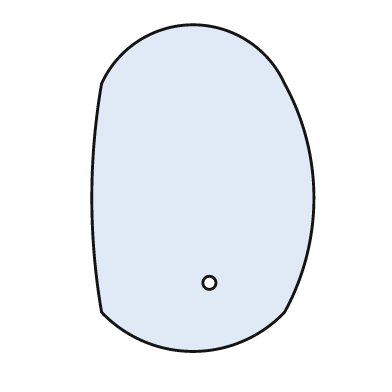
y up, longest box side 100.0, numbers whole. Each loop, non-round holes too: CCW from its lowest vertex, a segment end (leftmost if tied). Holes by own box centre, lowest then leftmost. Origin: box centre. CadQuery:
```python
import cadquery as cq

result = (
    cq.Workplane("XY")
    .moveTo(-31.0, -38.0)
    .threePointArc((-3.0, -50.0), (25.0, -38.0))
    .threePointArc((34.0, -3.0), (25.0, 32.0))
    .threePointArc((-3.0, 50.0), (-31.0, 32.0))
    .threePointArc((-34.0, -3.0), (-31.0, -38.0))
    .close()
    .moveTo(2.0, -29.0)
    .circle(2.0)
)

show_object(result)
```